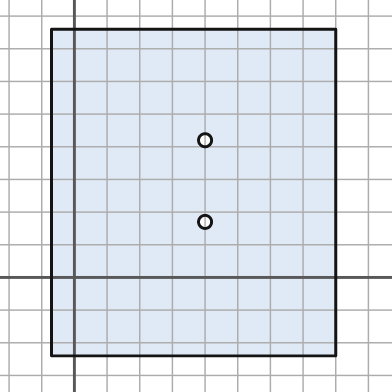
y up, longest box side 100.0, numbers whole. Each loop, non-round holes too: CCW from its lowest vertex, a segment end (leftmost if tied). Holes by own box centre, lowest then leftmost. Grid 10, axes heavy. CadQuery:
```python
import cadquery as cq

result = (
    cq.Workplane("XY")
    .moveTo(-7.0, -24.0)
    .lineTo(80.0, -24.0)
    .lineTo(80.0, 76.0)
    .lineTo(-7.0, 76.0)
    .close()
    .moveTo(40.0, 17.0)
    .circle(2.0)
    .moveTo(40.0, 42.0)
    .circle(2.0)
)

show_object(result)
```